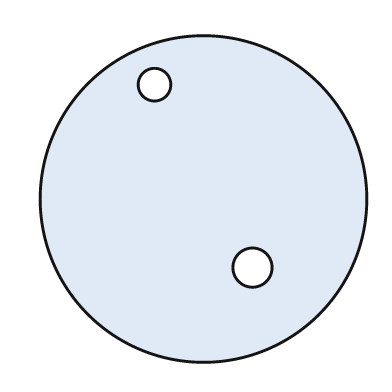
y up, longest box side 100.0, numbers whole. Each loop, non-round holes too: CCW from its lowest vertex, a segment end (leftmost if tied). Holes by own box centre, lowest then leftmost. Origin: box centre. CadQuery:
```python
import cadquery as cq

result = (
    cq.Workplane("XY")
    .moveTo(0.0, 0.0)
    .circle(50.0)
    .moveTo(15.0, -21.0)
    .circle(6.0)
    .moveTo(-15.0, 35.0)
    .circle(5.0)
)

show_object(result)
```